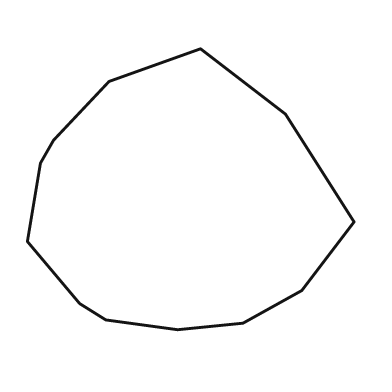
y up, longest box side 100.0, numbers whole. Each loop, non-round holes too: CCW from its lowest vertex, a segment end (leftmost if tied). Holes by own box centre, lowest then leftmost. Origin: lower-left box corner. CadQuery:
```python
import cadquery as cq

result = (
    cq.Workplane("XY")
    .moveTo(46.0, 0.0)
    .lineTo(66.0, 2.0)
    .lineTo(84.0, 12.0)
    .lineTo(100.0, 33.0)
    .lineTo(79.0, 66.0)
    .lineTo(53.0, 86.0)
    .lineTo(25.0, 76.0)
    .lineTo(8.0, 58.0)
    .lineTo(4.0, 51.0)
    .lineTo(0.0, 27.0)
    .lineTo(16.0, 8.0)
    .lineTo(24.0, 3.0)
    .close()
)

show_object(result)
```